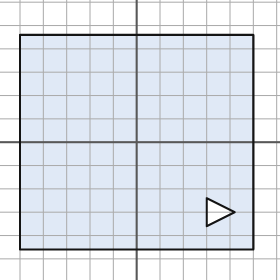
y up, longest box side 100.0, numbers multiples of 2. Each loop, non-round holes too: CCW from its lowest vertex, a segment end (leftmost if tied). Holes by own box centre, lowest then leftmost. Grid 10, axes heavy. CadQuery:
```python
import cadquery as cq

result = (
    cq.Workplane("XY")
    .moveTo(-50.0, -46.0)
    .lineTo(50.0, -46.0)
    .lineTo(50.0, 46.0)
    .lineTo(-50.0, 46.0)
    .close()
    .moveTo(30.0, -36.0)
    .lineTo(42.0, -30.0)
    .lineTo(30.0, -24.0)
    .close()
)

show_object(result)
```